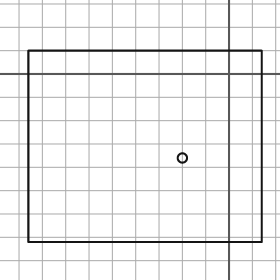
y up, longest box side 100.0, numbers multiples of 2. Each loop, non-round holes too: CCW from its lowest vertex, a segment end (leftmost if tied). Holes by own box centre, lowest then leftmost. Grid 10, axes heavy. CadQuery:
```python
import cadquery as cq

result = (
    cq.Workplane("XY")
    .moveTo(-86.0, -72.0)
    .lineTo(14.0, -72.0)
    .lineTo(14.0, 10.0)
    .lineTo(-86.0, 10.0)
    .close()
    .moveTo(-20.0, -36.0)
    .circle(2.0)
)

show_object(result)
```